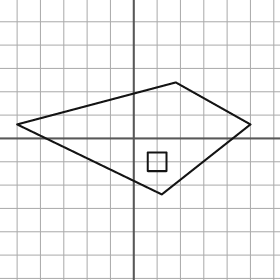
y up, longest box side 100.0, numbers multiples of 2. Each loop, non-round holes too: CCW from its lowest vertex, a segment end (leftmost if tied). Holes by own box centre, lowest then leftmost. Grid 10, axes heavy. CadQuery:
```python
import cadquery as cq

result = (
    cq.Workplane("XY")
    .moveTo(12.0, -24.0)
    .lineTo(50.0, 6.0)
    .lineTo(18.0, 24.0)
    .lineTo(-50.0, 6.0)
    .close()
    .moveTo(6.0, -14.0)
    .lineTo(14.0, -14.0)
    .lineTo(14.0, -6.0)
    .lineTo(6.0, -6.0)
    .close()
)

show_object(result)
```